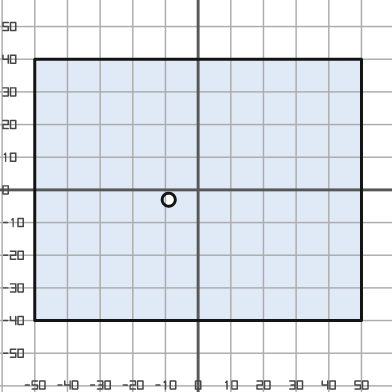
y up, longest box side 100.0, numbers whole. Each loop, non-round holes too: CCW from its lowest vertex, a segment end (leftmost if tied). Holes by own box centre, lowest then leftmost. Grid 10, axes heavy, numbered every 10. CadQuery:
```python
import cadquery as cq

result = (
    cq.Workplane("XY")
    .moveTo(-50.0, -40.0)
    .lineTo(50.0, -40.0)
    .lineTo(50.0, 40.0)
    .lineTo(-50.0, 40.0)
    .close()
    .moveTo(-9.0, -3.0)
    .circle(2.0)
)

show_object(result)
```